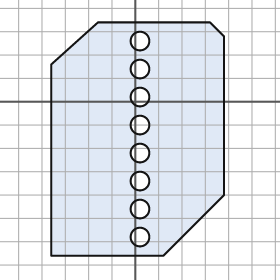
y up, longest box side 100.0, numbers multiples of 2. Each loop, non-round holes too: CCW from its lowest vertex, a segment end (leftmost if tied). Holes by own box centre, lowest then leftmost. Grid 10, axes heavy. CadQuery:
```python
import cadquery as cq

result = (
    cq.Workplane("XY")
    .moveTo(-36.0, -66.0)
    .lineTo(12.0, -66.0)
    .lineTo(38.0, -40.0)
    .lineTo(38.0, 28.0)
    .lineTo(32.0, 34.0)
    .lineTo(-16.0, 34.0)
    .lineTo(-36.0, 16.0)
    .close()
    .moveTo(2.0, -58.0)
    .circle(4.0)
    .moveTo(2.0, -46.0)
    .circle(4.0)
    .moveTo(2.0, -34.0)
    .circle(4.0)
    .moveTo(2.0, -22.0)
    .circle(4.0)
    .moveTo(2.0, -10.0)
    .circle(4.0)
    .moveTo(2.0, 2.0)
    .circle(4.0)
    .moveTo(2.0, 14.0)
    .circle(4.0)
    .moveTo(2.0, 26.0)
    .circle(4.0)
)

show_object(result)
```